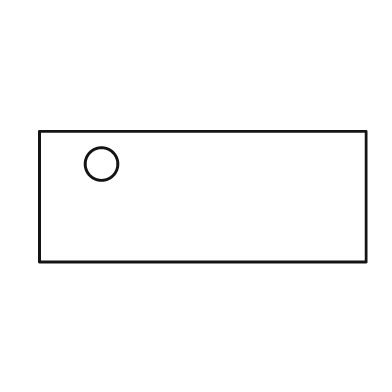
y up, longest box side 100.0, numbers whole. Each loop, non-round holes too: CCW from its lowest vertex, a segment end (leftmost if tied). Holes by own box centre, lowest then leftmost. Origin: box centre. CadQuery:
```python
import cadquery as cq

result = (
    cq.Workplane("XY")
    .moveTo(-50.0, -20.0)
    .lineTo(50.0, -20.0)
    .lineTo(50.0, 20.0)
    .lineTo(-50.0, 20.0)
    .close()
    .moveTo(-31.0, 10.0)
    .circle(5.0)
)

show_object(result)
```